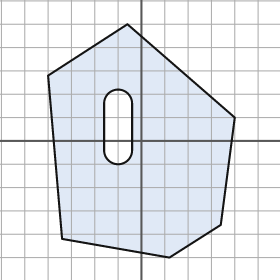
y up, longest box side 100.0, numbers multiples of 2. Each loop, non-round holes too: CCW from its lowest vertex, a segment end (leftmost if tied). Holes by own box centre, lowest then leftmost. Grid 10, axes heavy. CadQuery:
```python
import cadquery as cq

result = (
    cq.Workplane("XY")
    .moveTo(12.0, -50.0)
    .lineTo(34.0, -36.0)
    .lineTo(40.0, 10.0)
    .lineTo(-6.0, 50.0)
    .lineTo(-40.0, 28.0)
    .lineTo(-34.0, -42.0)
    .close()
    .moveTo(-16.0, -4.0)
    .threePointArc((-10.0, -10.0), (-4.0, -4.0))
    .lineTo(-4.0, 16.0)
    .threePointArc((-10.0, 22.0), (-16.0, 16.0))
    .close()
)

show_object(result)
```